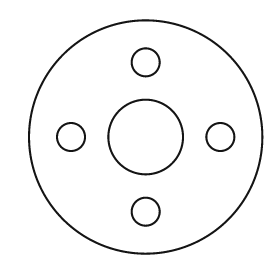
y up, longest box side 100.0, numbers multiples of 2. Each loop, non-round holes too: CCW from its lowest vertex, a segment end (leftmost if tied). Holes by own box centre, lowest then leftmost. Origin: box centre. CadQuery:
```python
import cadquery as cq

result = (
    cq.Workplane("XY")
    .moveTo(0.0, 0.0)
    .circle(50.0)
    .moveTo(0.0, -32.0)
    .circle(6.0)
    .moveTo(-32.0, 0.0)
    .circle(6.0)
    .moveTo(0.0, 0.0)
    .circle(16.0)
    .moveTo(32.0, 0.0)
    .circle(6.0)
    .moveTo(0.0, 32.0)
    .circle(6.0)
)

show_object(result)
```